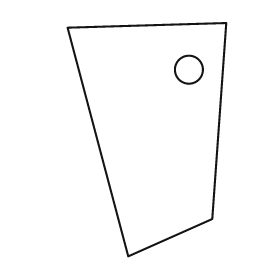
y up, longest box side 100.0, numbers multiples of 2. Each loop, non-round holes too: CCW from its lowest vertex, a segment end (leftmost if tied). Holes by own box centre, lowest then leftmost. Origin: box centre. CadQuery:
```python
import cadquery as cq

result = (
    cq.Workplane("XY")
    .moveTo(-8.0, -50.0)
    .lineTo(28.0, -34.0)
    .lineTo(34.0, 50.0)
    .lineTo(-34.0, 48.0)
    .close()
    .moveTo(18.0, 30.0)
    .circle(6.0)
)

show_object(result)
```